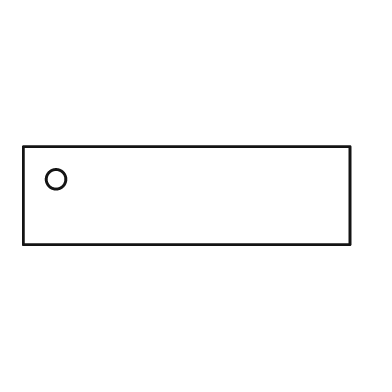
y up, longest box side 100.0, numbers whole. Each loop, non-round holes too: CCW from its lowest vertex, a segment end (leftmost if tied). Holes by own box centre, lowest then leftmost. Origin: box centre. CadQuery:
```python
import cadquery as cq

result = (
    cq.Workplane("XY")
    .moveTo(-50.0, -15.0)
    .lineTo(50.0, -15.0)
    .lineTo(50.0, 15.0)
    .lineTo(-50.0, 15.0)
    .close()
    .moveTo(-40.0, 5.0)
    .circle(3.0)
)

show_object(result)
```